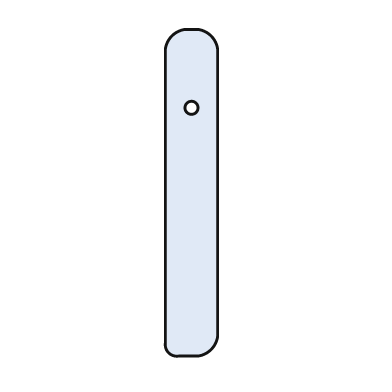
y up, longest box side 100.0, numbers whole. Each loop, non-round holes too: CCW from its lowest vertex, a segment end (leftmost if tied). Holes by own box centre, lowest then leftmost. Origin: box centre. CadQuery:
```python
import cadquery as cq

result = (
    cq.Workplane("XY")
    .moveTo(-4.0, -50.0)
    .lineTo(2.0, -50.0)
    .threePointArc((6.0, -48.0), (8.0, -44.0))
    .lineTo(8.0, 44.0)
    .threePointArc((6.0, 48.0), (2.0, 50.0))
    .lineTo(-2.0, 50.0)
    .threePointArc((-6.0, 48.0), (-8.0, 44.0))
    .lineTo(-8.0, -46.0)
    .threePointArc((-7.0, -49.0), (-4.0, -50.0))
    .close()
    .moveTo(0.0, 26.0)
    .circle(2.0)
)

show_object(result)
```